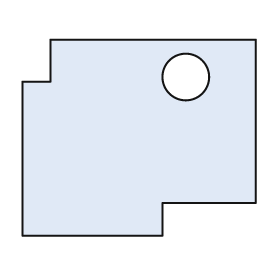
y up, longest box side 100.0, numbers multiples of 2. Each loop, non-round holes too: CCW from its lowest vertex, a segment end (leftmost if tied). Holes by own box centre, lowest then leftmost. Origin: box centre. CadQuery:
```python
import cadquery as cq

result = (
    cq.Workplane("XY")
    .moveTo(-50.0, -42.0)
    .lineTo(10.0, -42.0)
    .lineTo(10.0, -28.0)
    .lineTo(50.0, -28.0)
    .lineTo(50.0, 42.0)
    .lineTo(-38.0, 42.0)
    .lineTo(-38.0, 24.0)
    .lineTo(-50.0, 24.0)
    .close()
    .moveTo(20.0, 26.0)
    .circle(10.0)
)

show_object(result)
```